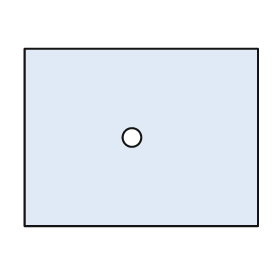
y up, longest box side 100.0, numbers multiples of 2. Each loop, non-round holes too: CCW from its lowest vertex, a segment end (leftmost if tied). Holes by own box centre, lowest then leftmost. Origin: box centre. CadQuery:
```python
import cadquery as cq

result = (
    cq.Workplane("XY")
    .moveTo(-50.0, -38.0)
    .lineTo(50.0, -38.0)
    .lineTo(50.0, 38.0)
    .lineTo(-50.0, 38.0)
    .close()
    .moveTo(-4.0, 0.0)
    .circle(4.0)
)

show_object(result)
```